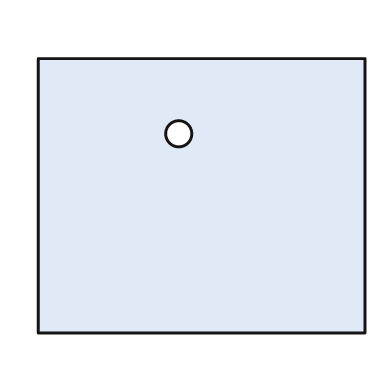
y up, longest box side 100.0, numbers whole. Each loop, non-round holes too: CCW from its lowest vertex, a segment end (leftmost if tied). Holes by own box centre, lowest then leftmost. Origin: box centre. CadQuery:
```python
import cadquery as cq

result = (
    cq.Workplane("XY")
    .moveTo(-50.0, -42.0)
    .lineTo(50.0, -42.0)
    .lineTo(50.0, 42.0)
    .lineTo(-50.0, 42.0)
    .close()
    .moveTo(-7.0, 19.0)
    .circle(4.0)
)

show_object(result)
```